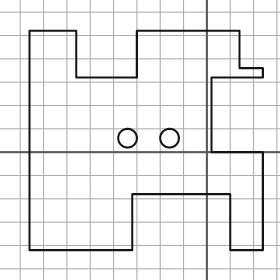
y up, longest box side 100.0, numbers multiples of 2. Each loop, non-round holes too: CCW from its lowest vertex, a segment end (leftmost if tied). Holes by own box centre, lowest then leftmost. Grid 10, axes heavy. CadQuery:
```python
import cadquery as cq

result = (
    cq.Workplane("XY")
    .moveTo(-76.0, -42.0)
    .lineTo(-32.0, -42.0)
    .lineTo(-32.0, -18.0)
    .lineTo(10.0, -18.0)
    .lineTo(10.0, -42.0)
    .lineTo(24.0, -42.0)
    .lineTo(24.0, 0.0)
    .lineTo(2.0, 0.0)
    .lineTo(2.0, 32.0)
    .lineTo(24.0, 32.0)
    .lineTo(24.0, 36.0)
    .lineTo(14.0, 36.0)
    .lineTo(14.0, 52.0)
    .lineTo(-30.0, 52.0)
    .lineTo(-30.0, 32.0)
    .lineTo(-56.0, 32.0)
    .lineTo(-56.0, 52.0)
    .lineTo(-76.0, 52.0)
    .close()
    .moveTo(-34.0, 6.0)
    .circle(4.0)
    .moveTo(-16.0, 6.0)
    .circle(4.0)
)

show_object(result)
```